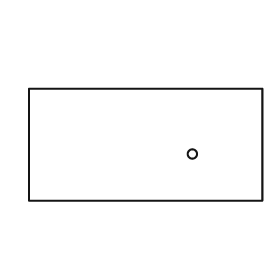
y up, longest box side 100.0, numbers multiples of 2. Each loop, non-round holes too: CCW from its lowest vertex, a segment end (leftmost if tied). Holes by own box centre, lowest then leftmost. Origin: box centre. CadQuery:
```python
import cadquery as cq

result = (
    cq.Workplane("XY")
    .moveTo(-50.0, -24.0)
    .lineTo(50.0, -24.0)
    .lineTo(50.0, 24.0)
    .lineTo(-50.0, 24.0)
    .close()
    .moveTo(20.0, -4.0)
    .circle(2.0)
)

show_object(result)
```